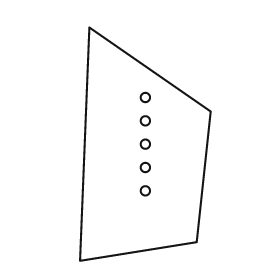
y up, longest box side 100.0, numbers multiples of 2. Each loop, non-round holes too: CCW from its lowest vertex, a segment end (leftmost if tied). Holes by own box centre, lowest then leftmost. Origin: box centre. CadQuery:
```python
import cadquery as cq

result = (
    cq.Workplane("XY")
    .moveTo(-28.0, -50.0)
    .lineTo(22.0, -42.0)
    .lineTo(28.0, 14.0)
    .lineTo(-24.0, 50.0)
    .close()
    .moveTo(0.0, -20.0)
    .circle(2.0)
    .moveTo(0.0, -10.0)
    .circle(2.0)
    .moveTo(0.0, 0.0)
    .circle(2.0)
    .moveTo(0.0, 10.0)
    .circle(2.0)
    .moveTo(0.0, 20.0)
    .circle(2.0)
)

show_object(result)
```